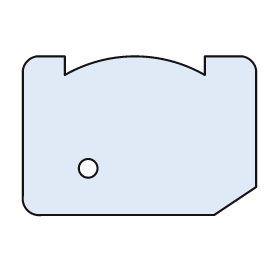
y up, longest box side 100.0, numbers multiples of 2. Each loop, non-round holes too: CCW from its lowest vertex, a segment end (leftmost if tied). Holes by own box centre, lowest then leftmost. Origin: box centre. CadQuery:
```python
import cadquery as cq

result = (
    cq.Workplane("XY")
    .moveTo(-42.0, -34.0)
    .lineTo(32.0, -34.0)
    .lineTo(50.0, -22.0)
    .lineTo(50.0, 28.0)
    .threePointArc((48.0, 32.0), (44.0, 34.0))
    .lineTo(28.0, 34.0)
    .lineTo(28.0, 26.0)
    .threePointArc((-2.0, 34.0), (-32.0, 26.0))
    .lineTo(-32.0, 34.0)
    .lineTo(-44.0, 34.0)
    .threePointArc((-48.0, 32.0), (-50.0, 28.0))
    .lineTo(-50.0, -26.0)
    .threePointArc((-48.0, -32.0), (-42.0, -34.0))
    .close()
    .moveTo(-22.0, -14.0)
    .circle(4.0)
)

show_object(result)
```